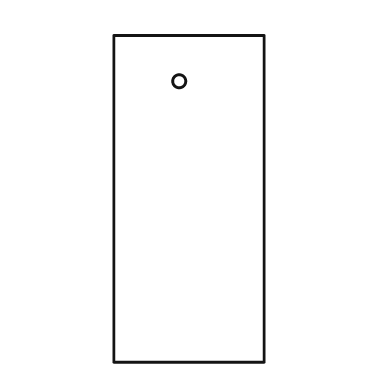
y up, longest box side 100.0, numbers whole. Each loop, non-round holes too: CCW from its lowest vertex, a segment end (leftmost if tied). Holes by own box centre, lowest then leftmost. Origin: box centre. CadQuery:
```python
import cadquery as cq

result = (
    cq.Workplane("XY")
    .moveTo(-23.0, -50.0)
    .lineTo(23.0, -50.0)
    .lineTo(23.0, 50.0)
    .lineTo(-23.0, 50.0)
    .close()
    .moveTo(-3.0, 36.0)
    .circle(2.0)
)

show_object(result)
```